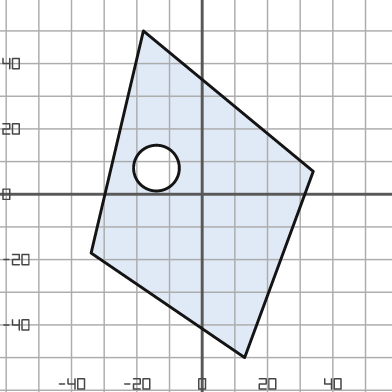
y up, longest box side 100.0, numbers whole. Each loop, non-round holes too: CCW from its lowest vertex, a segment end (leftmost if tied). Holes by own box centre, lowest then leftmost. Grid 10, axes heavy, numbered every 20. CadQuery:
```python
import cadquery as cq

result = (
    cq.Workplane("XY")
    .moveTo(13.0, -50.0)
    .lineTo(34.0, 7.0)
    .lineTo(-18.0, 50.0)
    .lineTo(-34.0, -18.0)
    .close()
    .moveTo(-14.0, 8.0)
    .circle(7.0)
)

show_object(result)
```